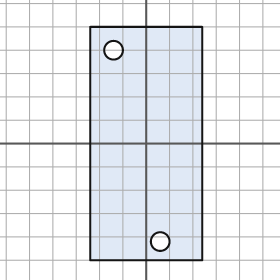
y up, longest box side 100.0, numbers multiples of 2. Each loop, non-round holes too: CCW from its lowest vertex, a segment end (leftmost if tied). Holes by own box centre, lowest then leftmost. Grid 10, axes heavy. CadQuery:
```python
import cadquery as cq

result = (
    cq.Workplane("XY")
    .moveTo(-24.0, -50.0)
    .lineTo(24.0, -50.0)
    .lineTo(24.0, 50.0)
    .lineTo(-24.0, 50.0)
    .close()
    .moveTo(6.0, -42.0)
    .circle(4.0)
    .moveTo(-14.0, 40.0)
    .circle(4.0)
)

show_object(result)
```